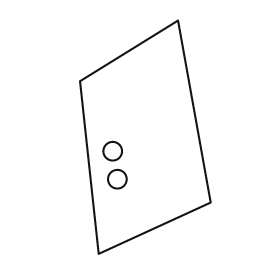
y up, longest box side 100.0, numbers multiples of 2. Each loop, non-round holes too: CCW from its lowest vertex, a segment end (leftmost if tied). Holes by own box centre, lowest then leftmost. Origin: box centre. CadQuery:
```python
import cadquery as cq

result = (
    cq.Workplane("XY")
    .moveTo(-20.0, -50.0)
    .lineTo(28.0, -28.0)
    .lineTo(14.0, 50.0)
    .lineTo(-28.0, 24.0)
    .close()
    .moveTo(-12.0, -18.0)
    .circle(4.0)
    .moveTo(-14.0, -6.0)
    .circle(4.0)
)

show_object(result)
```